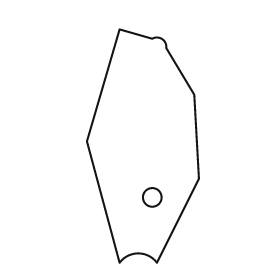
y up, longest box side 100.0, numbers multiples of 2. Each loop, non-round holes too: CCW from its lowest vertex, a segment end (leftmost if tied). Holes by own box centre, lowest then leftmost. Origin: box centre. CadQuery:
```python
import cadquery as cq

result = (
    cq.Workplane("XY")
    .moveTo(-10.0, -50.0)
    .threePointArc((-2.0, -46.0), (6.0, -50.0))
    .lineTo(24.0, -14.0)
    .lineTo(22.0, 22.0)
    .lineTo(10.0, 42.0)
    .threePointArc((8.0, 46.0), (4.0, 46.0))
    .lineTo(-10.0, 50.0)
    .lineTo(-24.0, 2.0)
    .close()
    .moveTo(4.0, -22.0)
    .circle(4.0)
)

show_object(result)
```